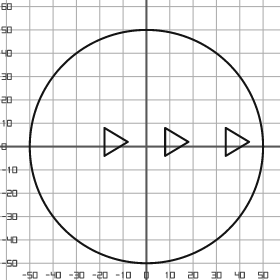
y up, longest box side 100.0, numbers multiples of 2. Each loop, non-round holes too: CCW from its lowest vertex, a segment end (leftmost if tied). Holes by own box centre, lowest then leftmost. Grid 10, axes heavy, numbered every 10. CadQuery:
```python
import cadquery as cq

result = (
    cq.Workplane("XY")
    .moveTo(0.0, 0.0)
    .circle(50.0)
    .moveTo(-18.0, -4.0)
    .lineTo(-8.0, 2.0)
    .lineTo(-18.0, 8.0)
    .close()
    .moveTo(8.0, -4.0)
    .lineTo(18.0, 2.0)
    .lineTo(8.0, 8.0)
    .close()
    .moveTo(34.0, -4.0)
    .lineTo(44.0, 2.0)
    .lineTo(34.0, 8.0)
    .close()
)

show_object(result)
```